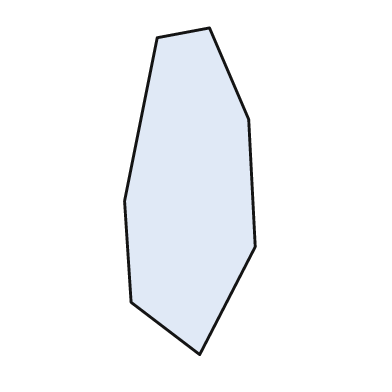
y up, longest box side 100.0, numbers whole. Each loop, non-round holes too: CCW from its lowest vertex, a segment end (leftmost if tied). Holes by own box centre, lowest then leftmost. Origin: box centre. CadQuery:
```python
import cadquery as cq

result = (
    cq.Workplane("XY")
    .moveTo(3.0, -50.0)
    .lineTo(20.0, -17.0)
    .lineTo(18.0, 22.0)
    .lineTo(6.0, 50.0)
    .lineTo(-10.0, 47.0)
    .lineTo(-20.0, -3.0)
    .lineTo(-18.0, -34.0)
    .close()
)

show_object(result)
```